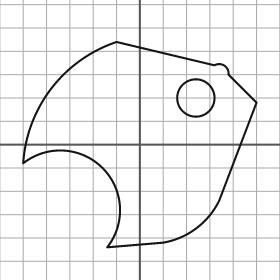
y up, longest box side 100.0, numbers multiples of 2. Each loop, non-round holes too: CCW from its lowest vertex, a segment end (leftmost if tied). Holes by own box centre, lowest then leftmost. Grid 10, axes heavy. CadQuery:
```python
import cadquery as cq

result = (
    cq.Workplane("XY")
    .moveTo(-14.0, -44.0)
    .lineTo(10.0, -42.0)
    .threePointArc((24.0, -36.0), (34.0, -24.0))
    .lineTo(50.0, 18.0)
    .lineTo(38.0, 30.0)
    .threePointArc((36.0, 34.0), (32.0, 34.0))
    .lineTo(-10.0, 44.0)
    .threePointArc((-38.0, 24.0), (-50.0, -8.0))
    .threePointArc((-16.0, -10.0), (-14.0, -44.0))
    .close()
    .moveTo(24.0, 20.0)
    .circle(8.0)
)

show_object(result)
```